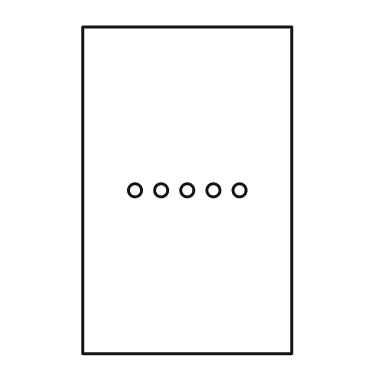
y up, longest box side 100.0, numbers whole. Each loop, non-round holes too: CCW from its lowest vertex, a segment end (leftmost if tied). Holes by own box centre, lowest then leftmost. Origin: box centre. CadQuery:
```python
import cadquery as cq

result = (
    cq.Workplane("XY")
    .moveTo(-32.0, -50.0)
    .lineTo(32.0, -50.0)
    .lineTo(32.0, 50.0)
    .lineTo(-32.0, 50.0)
    .close()
    .moveTo(-16.0, 0.0)
    .circle(2.0)
    .moveTo(-8.0, 0.0)
    .circle(2.0)
    .moveTo(0.0, 0.0)
    .circle(2.0)
    .moveTo(8.0, 0.0)
    .circle(2.0)
    .moveTo(16.0, 0.0)
    .circle(2.0)
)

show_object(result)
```